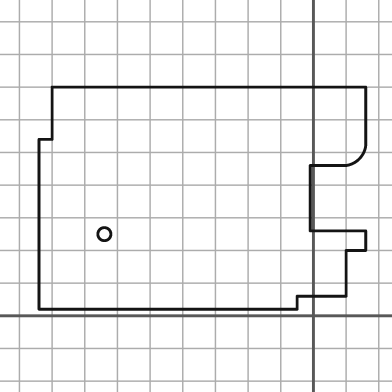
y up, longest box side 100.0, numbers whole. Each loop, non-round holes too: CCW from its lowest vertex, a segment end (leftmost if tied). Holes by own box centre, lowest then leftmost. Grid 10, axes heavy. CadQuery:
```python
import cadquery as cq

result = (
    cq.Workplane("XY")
    .moveTo(-84.0, 2.0)
    .lineTo(-5.0, 2.0)
    .lineTo(-5.0, 6.0)
    .lineTo(10.0, 6.0)
    .lineTo(10.0, 20.0)
    .lineTo(16.0, 20.0)
    .lineTo(16.0, 26.0)
    .lineTo(-1.0, 26.0)
    .lineTo(-1.0, 46.0)
    .lineTo(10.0, 46.0)
    .threePointArc((14.0, 48.0), (16.0, 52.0))
    .lineTo(16.0, 70.0)
    .lineTo(-80.0, 70.0)
    .lineTo(-80.0, 54.0)
    .lineTo(-84.0, 54.0)
    .close()
    .moveTo(-64.0, 25.0)
    .circle(2.0)
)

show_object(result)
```